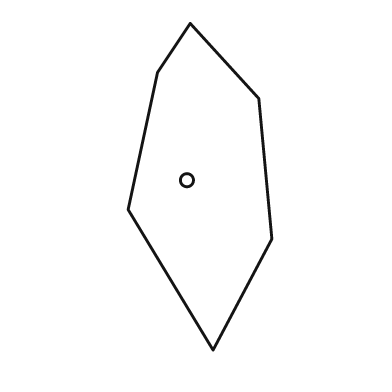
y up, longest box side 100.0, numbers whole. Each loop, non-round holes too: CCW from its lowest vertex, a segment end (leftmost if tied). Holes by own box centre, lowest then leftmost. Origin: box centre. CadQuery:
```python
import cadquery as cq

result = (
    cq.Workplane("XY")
    .moveTo(4.0, -50.0)
    .lineTo(22.0, -16.0)
    .lineTo(18.0, 27.0)
    .lineTo(-3.0, 50.0)
    .lineTo(-13.0, 35.0)
    .lineTo(-22.0, -7.0)
    .close()
    .moveTo(-4.0, 2.0)
    .circle(2.0)
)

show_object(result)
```